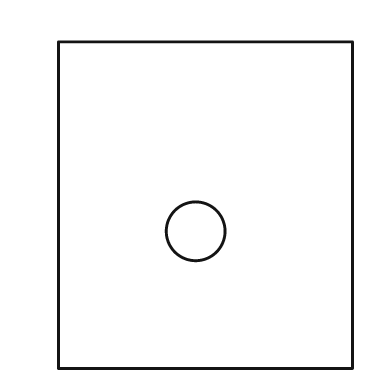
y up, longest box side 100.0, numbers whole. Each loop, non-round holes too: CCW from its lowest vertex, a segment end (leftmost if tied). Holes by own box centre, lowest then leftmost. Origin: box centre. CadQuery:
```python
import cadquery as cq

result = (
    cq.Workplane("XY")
    .moveTo(-45.0, -50.0)
    .lineTo(45.0, -50.0)
    .lineTo(45.0, 50.0)
    .lineTo(-45.0, 50.0)
    .close()
    .moveTo(-3.0, -8.0)
    .circle(9.0)
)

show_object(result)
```